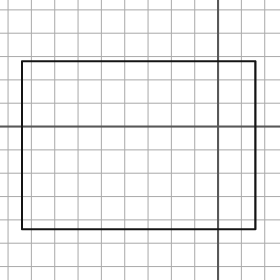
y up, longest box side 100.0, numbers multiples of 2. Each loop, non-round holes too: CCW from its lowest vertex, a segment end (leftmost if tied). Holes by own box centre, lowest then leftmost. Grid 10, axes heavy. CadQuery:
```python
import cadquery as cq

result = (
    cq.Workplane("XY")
    .moveTo(-84.0, -44.0)
    .lineTo(16.0, -44.0)
    .lineTo(16.0, 28.0)
    .lineTo(-84.0, 28.0)
    .close()
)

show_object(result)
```